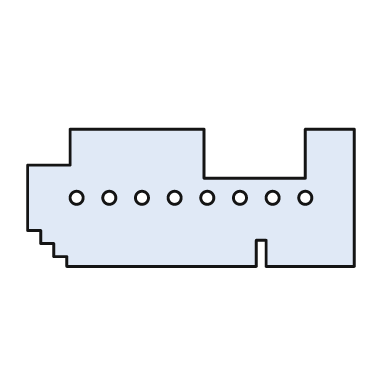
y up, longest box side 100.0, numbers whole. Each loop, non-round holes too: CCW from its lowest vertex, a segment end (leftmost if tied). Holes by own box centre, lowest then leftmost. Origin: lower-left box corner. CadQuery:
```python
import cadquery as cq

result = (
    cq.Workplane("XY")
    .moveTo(12.0, 0.0)
    .lineTo(70.0, 0.0)
    .lineTo(70.0, 8.0)
    .lineTo(73.0, 8.0)
    .lineTo(73.0, 0.0)
    .lineTo(100.0, 0.0)
    .lineTo(100.0, 42.0)
    .lineTo(85.0, 42.0)
    .lineTo(85.0, 27.0)
    .lineTo(54.0, 27.0)
    .lineTo(54.0, 42.0)
    .lineTo(13.0, 42.0)
    .lineTo(13.0, 31.0)
    .lineTo(0.0, 31.0)
    .lineTo(0.0, 11.0)
    .lineTo(4.0, 11.0)
    .lineTo(4.0, 7.0)
    .lineTo(8.0, 7.0)
    .lineTo(8.0, 3.0)
    .lineTo(12.0, 3.0)
    .close()
    .moveTo(15.0, 21.0)
    .circle(2.0)
    .moveTo(25.0, 21.0)
    .circle(2.0)
    .moveTo(35.0, 21.0)
    .circle(2.0)
    .moveTo(45.0, 21.0)
    .circle(2.0)
    .moveTo(55.0, 21.0)
    .circle(2.0)
    .moveTo(65.0, 21.0)
    .circle(2.0)
    .moveTo(75.0, 21.0)
    .circle(2.0)
    .moveTo(85.0, 21.0)
    .circle(2.0)
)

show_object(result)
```